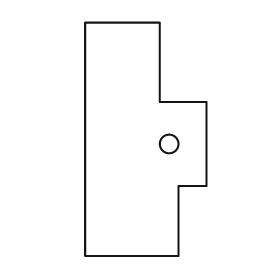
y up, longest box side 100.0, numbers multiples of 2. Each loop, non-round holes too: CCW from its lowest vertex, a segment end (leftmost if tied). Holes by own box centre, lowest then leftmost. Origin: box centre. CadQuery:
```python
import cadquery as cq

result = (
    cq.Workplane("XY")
    .moveTo(-26.0, -50.0)
    .lineTo(14.0, -50.0)
    .lineTo(14.0, -20.0)
    .lineTo(26.0, -20.0)
    .lineTo(26.0, 16.0)
    .lineTo(6.0, 16.0)
    .lineTo(6.0, 50.0)
    .lineTo(-26.0, 50.0)
    .close()
    .moveTo(10.0, -2.0)
    .circle(4.0)
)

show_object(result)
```